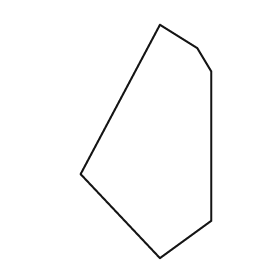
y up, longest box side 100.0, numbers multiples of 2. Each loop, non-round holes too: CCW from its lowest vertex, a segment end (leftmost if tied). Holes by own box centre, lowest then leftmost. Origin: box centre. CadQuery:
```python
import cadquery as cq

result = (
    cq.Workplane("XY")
    .moveTo(6.0, -50.0)
    .lineTo(28.0, -34.0)
    .lineTo(28.0, 30.0)
    .lineTo(22.0, 40.0)
    .lineTo(6.0, 50.0)
    .lineTo(-28.0, -14.0)
    .close()
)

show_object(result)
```